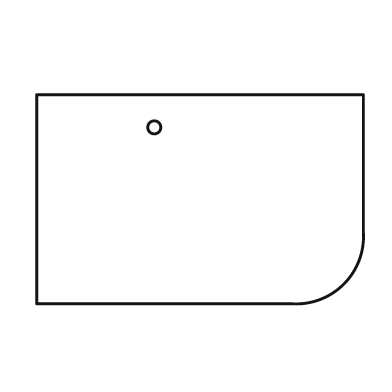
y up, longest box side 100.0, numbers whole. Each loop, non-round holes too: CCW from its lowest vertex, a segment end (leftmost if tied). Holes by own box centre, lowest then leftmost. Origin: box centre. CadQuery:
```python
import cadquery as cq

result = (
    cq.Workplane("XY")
    .moveTo(-50.0, -32.0)
    .lineTo(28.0, -32.0)
    .threePointArc((44.0, -26.0), (50.0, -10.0))
    .lineTo(50.0, 32.0)
    .lineTo(-50.0, 32.0)
    .close()
    .moveTo(-14.0, 22.0)
    .circle(2.0)
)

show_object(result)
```